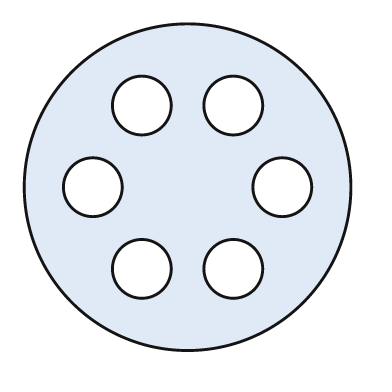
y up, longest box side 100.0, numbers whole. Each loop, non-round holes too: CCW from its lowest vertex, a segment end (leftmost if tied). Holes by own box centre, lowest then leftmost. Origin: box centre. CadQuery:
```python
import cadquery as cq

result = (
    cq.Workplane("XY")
    .moveTo(0.0, 0.0)
    .circle(50.0)
    .moveTo(-14.0, -25.0)
    .circle(9.0)
    .moveTo(14.0, -25.0)
    .circle(9.0)
    .moveTo(-29.0, 0.0)
    .circle(9.0)
    .moveTo(29.0, 0.0)
    .circle(9.0)
    .moveTo(-14.0, 25.0)
    .circle(9.0)
    .moveTo(14.0, 25.0)
    .circle(9.0)
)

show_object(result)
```